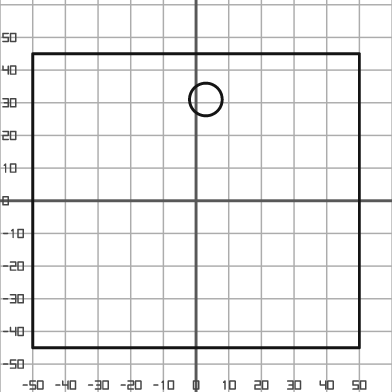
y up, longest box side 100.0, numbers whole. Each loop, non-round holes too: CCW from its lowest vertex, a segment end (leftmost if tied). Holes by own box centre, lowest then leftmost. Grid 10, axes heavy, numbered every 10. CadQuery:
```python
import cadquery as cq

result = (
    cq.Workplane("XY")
    .moveTo(-50.0, -45.0)
    .lineTo(50.0, -45.0)
    .lineTo(50.0, 45.0)
    .lineTo(-50.0, 45.0)
    .close()
    .moveTo(3.0, 31.0)
    .circle(5.0)
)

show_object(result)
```